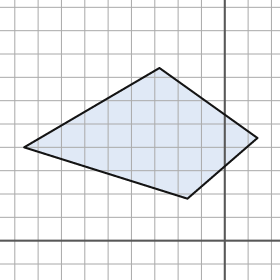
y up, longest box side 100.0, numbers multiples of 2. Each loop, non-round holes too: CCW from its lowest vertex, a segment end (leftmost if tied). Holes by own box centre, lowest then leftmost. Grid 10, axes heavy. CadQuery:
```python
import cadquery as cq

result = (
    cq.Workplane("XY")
    .moveTo(-16.0, 18.0)
    .lineTo(14.0, 44.0)
    .lineTo(-28.0, 74.0)
    .lineTo(-86.0, 40.0)
    .close()
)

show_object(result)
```